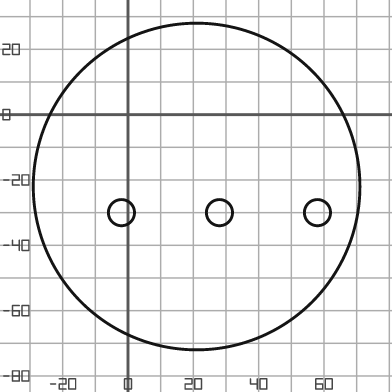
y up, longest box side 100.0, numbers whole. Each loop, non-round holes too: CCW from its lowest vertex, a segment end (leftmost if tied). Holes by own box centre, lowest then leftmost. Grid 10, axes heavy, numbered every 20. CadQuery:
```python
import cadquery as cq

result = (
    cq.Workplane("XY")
    .moveTo(21.0, -22.0)
    .circle(50.0)
    .moveTo(-2.0, -30.0)
    .circle(4.0)
    .moveTo(28.0, -30.0)
    .circle(4.0)
    .moveTo(58.0, -30.0)
    .circle(4.0)
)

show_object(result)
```